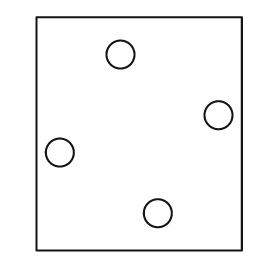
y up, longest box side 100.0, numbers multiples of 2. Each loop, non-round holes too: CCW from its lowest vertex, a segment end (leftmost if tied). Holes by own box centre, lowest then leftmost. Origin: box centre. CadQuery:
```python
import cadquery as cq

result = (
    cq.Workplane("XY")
    .moveTo(-44.0, -50.0)
    .lineTo(44.0, -50.0)
    .lineTo(44.0, 50.0)
    .lineTo(-44.0, 50.0)
    .close()
    .moveTo(8.0, -34.0)
    .circle(6.0)
    .moveTo(-34.0, -8.0)
    .circle(6.0)
    .moveTo(34.0, 8.0)
    .circle(6.0)
    .moveTo(-8.0, 34.0)
    .circle(6.0)
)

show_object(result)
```